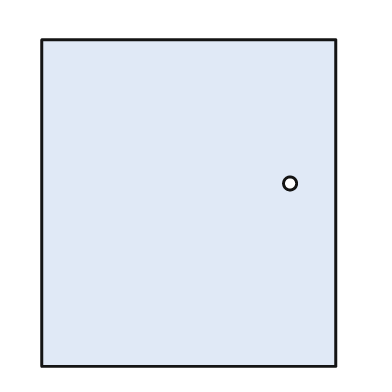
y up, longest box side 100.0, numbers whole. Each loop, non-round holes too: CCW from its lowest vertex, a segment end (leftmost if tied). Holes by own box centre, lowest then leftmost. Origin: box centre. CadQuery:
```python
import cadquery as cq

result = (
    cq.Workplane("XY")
    .moveTo(-45.0, -50.0)
    .lineTo(45.0, -50.0)
    .lineTo(45.0, 50.0)
    .lineTo(-45.0, 50.0)
    .close()
    .moveTo(31.0, 6.0)
    .circle(2.0)
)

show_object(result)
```